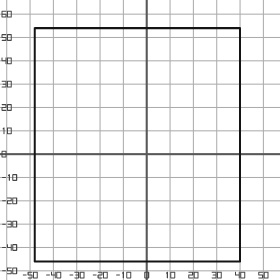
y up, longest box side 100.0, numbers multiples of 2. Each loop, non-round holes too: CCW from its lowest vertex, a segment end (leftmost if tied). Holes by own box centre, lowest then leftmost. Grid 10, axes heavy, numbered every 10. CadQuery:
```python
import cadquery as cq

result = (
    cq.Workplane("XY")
    .moveTo(-48.0, -46.0)
    .lineTo(40.0, -46.0)
    .lineTo(40.0, 54.0)
    .lineTo(-48.0, 54.0)
    .close()
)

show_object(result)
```